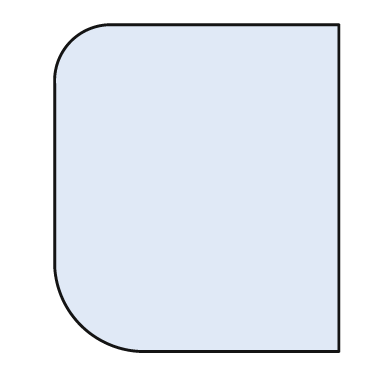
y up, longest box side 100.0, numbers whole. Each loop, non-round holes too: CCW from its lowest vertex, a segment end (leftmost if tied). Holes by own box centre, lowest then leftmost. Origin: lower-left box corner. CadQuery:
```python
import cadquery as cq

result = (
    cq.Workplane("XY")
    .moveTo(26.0, 0.0)
    .lineTo(87.0, 0.0)
    .lineTo(87.0, 100.0)
    .lineTo(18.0, 100.0)
    .threePointArc((5.0, 95.0), (0.0, 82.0))
    .lineTo(0.0, 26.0)
    .threePointArc((8.0, 8.0), (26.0, 0.0))
    .close()
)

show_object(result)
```